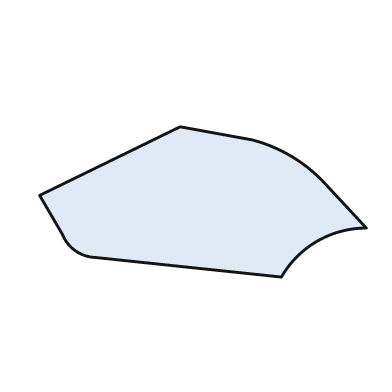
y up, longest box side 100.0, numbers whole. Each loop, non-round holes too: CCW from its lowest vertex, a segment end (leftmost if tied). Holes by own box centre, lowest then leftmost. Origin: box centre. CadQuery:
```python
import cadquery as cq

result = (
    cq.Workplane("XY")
    .moveTo(24.0, -23.0)
    .threePointArc((35.0, -12.0), (50.0, -8.0))
    .lineTo(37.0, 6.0)
    .threePointArc((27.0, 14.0), (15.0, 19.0))
    .lineTo(-7.0, 23.0)
    .lineTo(-50.0, 2.0)
    .lineTo(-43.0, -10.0)
    .threePointArc((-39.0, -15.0), (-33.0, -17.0))
    .close()
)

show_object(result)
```